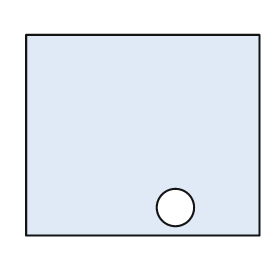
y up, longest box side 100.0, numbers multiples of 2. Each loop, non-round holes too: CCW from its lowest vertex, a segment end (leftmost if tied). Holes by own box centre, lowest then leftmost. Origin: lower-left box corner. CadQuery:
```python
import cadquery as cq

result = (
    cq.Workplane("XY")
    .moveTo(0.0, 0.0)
    .lineTo(100.0, 0.0)
    .lineTo(100.0, 86.0)
    .lineTo(0.0, 86.0)
    .close()
    .moveTo(64.0, 12.0)
    .circle(8.0)
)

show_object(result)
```